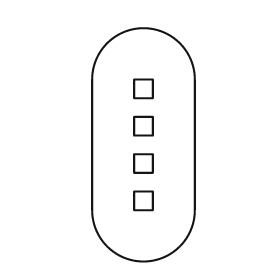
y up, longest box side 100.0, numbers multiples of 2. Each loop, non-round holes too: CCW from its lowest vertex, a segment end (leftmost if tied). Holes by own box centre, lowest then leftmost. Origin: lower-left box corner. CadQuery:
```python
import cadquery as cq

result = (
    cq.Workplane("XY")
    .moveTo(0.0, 22.0)
    .threePointArc((22.0, 0.0), (44.0, 22.0))
    .lineTo(44.0, 78.0)
    .threePointArc((22.0, 100.0), (0.0, 78.0))
    .close()
    .moveTo(18.0, 22.0)
    .lineTo(26.0, 22.0)
    .lineTo(26.0, 30.0)
    .lineTo(18.0, 30.0)
    .close()
    .moveTo(18.0, 38.0)
    .lineTo(26.0, 38.0)
    .lineTo(26.0, 46.0)
    .lineTo(18.0, 46.0)
    .close()
    .moveTo(18.0, 54.0)
    .lineTo(26.0, 54.0)
    .lineTo(26.0, 62.0)
    .lineTo(18.0, 62.0)
    .close()
    .moveTo(18.0, 70.0)
    .lineTo(26.0, 70.0)
    .lineTo(26.0, 78.0)
    .lineTo(18.0, 78.0)
    .close()
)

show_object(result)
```